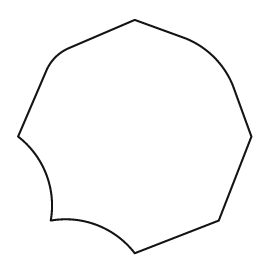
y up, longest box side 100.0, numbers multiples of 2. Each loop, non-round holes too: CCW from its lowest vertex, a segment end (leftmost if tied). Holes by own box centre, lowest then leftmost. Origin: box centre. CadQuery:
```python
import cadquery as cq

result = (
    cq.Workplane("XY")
    .moveTo(0.0, -50.0)
    .lineTo(36.0, -36.0)
    .lineTo(50.0, 0.0)
    .lineTo(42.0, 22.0)
    .threePointArc((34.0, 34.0), (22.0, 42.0))
    .lineTo(0.0, 50.0)
    .lineTo(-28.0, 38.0)
    .threePointArc((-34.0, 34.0), (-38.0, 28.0))
    .lineTo(-50.0, 0.0)
    .threePointArc((-38.0, -16.0), (-36.0, -36.0))
    .threePointArc((-16.0, -38.0), (0.0, -50.0))
    .close()
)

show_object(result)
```